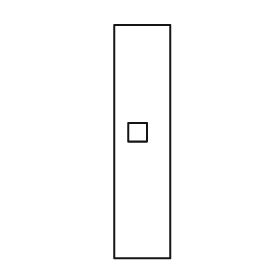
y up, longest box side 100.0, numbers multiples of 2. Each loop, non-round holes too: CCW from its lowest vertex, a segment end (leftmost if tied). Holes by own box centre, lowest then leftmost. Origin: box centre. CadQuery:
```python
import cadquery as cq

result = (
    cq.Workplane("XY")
    .moveTo(-12.0, -50.0)
    .lineTo(12.0, -50.0)
    .lineTo(12.0, 50.0)
    .lineTo(-12.0, 50.0)
    .close()
    .moveTo(-6.0, 0.0)
    .lineTo(2.0, 0.0)
    .lineTo(2.0, 8.0)
    .lineTo(-6.0, 8.0)
    .close()
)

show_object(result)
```